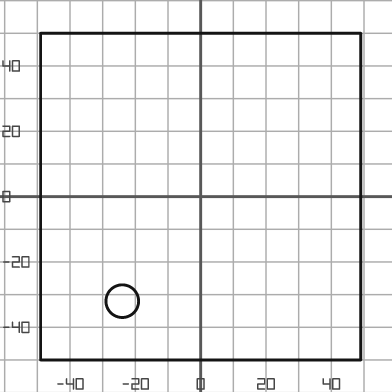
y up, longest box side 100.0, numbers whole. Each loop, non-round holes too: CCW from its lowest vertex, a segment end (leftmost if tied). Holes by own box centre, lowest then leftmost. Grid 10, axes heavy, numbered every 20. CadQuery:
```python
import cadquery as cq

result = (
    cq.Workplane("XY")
    .moveTo(-49.0, -50.0)
    .lineTo(49.0, -50.0)
    .lineTo(49.0, 50.0)
    .lineTo(-49.0, 50.0)
    .close()
    .moveTo(-24.0, -32.0)
    .circle(5.0)
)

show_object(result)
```